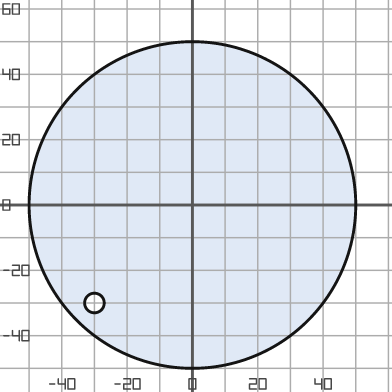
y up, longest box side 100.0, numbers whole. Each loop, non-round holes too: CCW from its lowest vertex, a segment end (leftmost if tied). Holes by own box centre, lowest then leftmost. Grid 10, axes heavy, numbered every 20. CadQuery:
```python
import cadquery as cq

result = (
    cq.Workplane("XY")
    .moveTo(0.0, 0.0)
    .circle(50.0)
    .moveTo(-30.0, -30.0)
    .circle(3.0)
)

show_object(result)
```